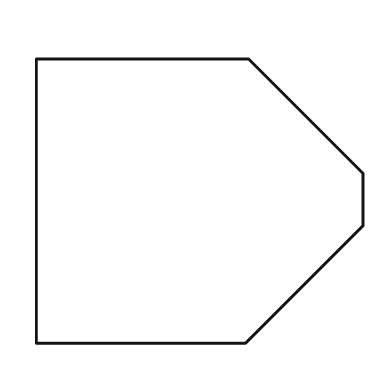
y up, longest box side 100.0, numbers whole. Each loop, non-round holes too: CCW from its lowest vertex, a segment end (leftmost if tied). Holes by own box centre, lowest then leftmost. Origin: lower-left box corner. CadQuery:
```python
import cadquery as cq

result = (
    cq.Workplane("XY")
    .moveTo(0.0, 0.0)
    .lineTo(64.0, 0.0)
    .lineTo(100.0, 36.0)
    .lineTo(100.0, 52.0)
    .lineTo(65.0, 87.0)
    .lineTo(0.0, 87.0)
    .close()
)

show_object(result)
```